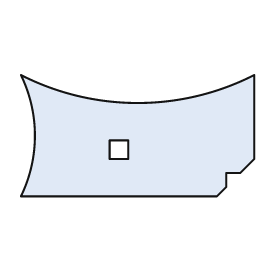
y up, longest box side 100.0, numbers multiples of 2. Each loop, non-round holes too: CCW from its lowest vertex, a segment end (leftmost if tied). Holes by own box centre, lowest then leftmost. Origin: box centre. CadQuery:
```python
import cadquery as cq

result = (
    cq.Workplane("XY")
    .moveTo(-50.0, -26.0)
    .lineTo(34.0, -26.0)
    .lineTo(38.0, -22.0)
    .lineTo(38.0, -16.0)
    .lineTo(44.0, -16.0)
    .lineTo(50.0, -10.0)
    .lineTo(50.0, 26.0)
    .threePointArc((0.0, 14.0), (-50.0, 26.0))
    .threePointArc((-44.0, 0.0), (-50.0, -26.0))
    .close()
    .moveTo(-12.0, -10.0)
    .lineTo(-4.0, -10.0)
    .lineTo(-4.0, -2.0)
    .lineTo(-12.0, -2.0)
    .close()
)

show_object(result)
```